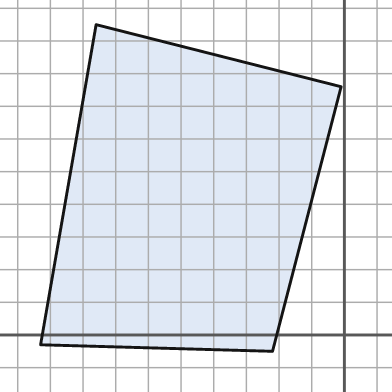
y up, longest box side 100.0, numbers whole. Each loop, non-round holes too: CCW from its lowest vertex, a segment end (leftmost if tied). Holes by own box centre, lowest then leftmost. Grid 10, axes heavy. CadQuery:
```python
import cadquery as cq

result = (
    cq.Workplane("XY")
    .moveTo(-22.0, -5.0)
    .lineTo(-1.0, 76.0)
    .lineTo(-76.0, 95.0)
    .lineTo(-93.0, -3.0)
    .close()
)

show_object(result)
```